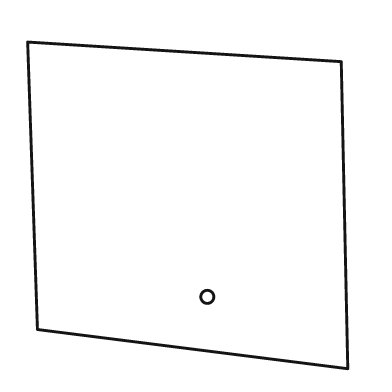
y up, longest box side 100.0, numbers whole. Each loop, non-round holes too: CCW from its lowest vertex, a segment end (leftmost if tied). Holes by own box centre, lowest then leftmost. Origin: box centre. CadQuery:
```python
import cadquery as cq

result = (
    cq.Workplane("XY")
    .moveTo(49.0, -50.0)
    .lineTo(47.0, 44.0)
    .lineTo(-49.0, 50.0)
    .lineTo(-46.0, -38.0)
    .close()
    .moveTo(6.0, -28.0)
    .circle(2.0)
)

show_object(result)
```